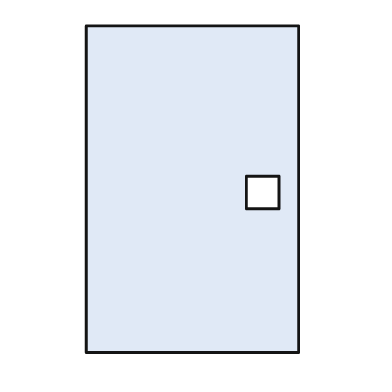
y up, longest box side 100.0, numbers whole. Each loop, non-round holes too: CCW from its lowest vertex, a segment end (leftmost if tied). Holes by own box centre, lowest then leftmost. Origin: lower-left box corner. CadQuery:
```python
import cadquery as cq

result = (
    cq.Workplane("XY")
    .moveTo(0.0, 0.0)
    .lineTo(65.0, 0.0)
    .lineTo(65.0, 100.0)
    .lineTo(0.0, 100.0)
    .close()
    .moveTo(49.0, 44.0)
    .lineTo(59.0, 44.0)
    .lineTo(59.0, 54.0)
    .lineTo(49.0, 54.0)
    .close()
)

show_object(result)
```